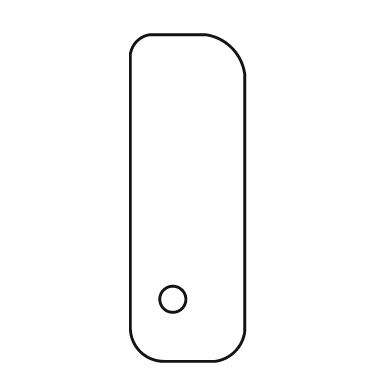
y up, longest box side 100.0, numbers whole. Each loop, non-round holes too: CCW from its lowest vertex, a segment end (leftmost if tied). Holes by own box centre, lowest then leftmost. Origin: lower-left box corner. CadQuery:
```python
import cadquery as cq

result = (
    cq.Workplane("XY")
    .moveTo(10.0, 0.0)
    .lineTo(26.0, 0.0)
    .threePointArc((32.0, 3.0), (35.0, 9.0))
    .lineTo(35.0, 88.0)
    .threePointArc((31.0, 96.0), (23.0, 100.0))
    .lineTo(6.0, 100.0)
    .threePointArc((2.0, 98.0), (0.0, 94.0))
    .lineTo(0.0, 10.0)
    .threePointArc((3.0, 3.0), (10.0, 0.0))
    .close()
    .moveTo(13.0, 19.0)
    .circle(4.0)
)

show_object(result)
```